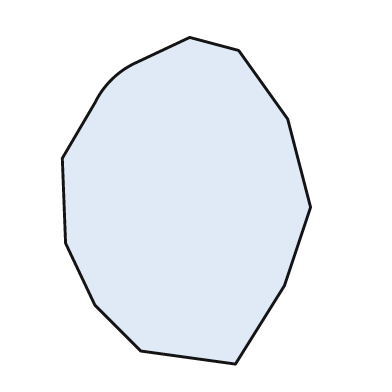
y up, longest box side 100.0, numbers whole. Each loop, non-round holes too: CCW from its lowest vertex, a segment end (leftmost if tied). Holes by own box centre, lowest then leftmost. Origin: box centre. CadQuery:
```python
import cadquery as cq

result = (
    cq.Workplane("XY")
    .moveTo(15.0, -50.0)
    .lineTo(30.0, -26.0)
    .lineTo(38.0, -2.0)
    .lineTo(31.0, 25.0)
    .lineTo(16.0, 46.0)
    .lineTo(1.0, 50.0)
    .lineTo(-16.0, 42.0)
    .threePointArc((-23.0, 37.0), (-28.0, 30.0))
    .lineTo(-38.0, 13.0)
    .lineTo(-37.0, -13.0)
    .lineTo(-28.0, -32.0)
    .lineTo(-14.0, -46.0)
    .close()
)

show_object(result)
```